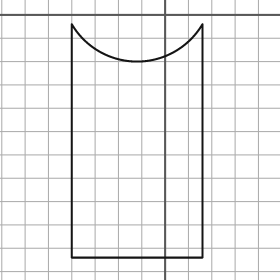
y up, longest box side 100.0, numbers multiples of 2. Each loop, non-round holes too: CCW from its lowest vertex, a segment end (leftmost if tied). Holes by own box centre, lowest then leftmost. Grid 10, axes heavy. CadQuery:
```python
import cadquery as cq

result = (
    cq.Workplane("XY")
    .moveTo(-40.0, -104.0)
    .lineTo(16.0, -104.0)
    .lineTo(16.0, -4.0)
    .threePointArc((-12.0, -20.0), (-40.0, -4.0))
    .close()
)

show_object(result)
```